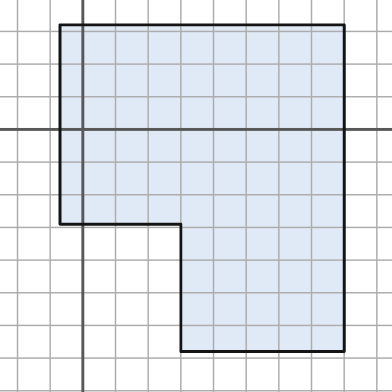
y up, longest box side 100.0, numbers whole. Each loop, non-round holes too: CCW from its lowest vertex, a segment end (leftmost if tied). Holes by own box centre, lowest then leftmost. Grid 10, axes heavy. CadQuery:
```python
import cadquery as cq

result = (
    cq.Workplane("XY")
    .moveTo(30.0, -68.0)
    .lineTo(80.0, -68.0)
    .lineTo(80.0, 32.0)
    .lineTo(-7.0, 32.0)
    .lineTo(-7.0, -29.0)
    .lineTo(30.0, -29.0)
    .close()
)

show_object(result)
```